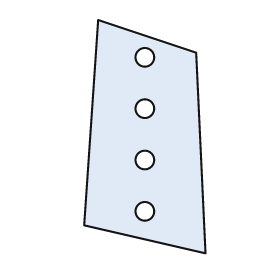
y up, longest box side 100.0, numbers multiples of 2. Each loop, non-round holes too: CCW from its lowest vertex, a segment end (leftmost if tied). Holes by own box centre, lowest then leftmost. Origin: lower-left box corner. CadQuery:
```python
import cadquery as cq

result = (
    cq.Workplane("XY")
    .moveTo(52.0, 0.0)
    .lineTo(48.0, 86.0)
    .lineTo(6.0, 100.0)
    .lineTo(0.0, 12.0)
    .close()
    .moveTo(26.0, 18.0)
    .circle(4.0)
    .moveTo(26.0, 40.0)
    .circle(4.0)
    .moveTo(26.0, 62.0)
    .circle(4.0)
    .moveTo(26.0, 84.0)
    .circle(4.0)
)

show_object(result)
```